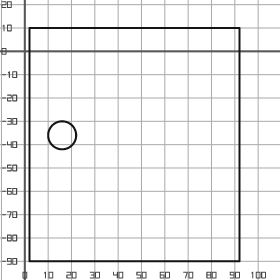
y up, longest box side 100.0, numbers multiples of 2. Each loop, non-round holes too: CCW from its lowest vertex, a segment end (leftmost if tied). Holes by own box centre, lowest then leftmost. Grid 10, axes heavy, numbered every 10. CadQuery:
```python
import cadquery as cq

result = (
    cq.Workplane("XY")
    .moveTo(2.0, -90.0)
    .lineTo(92.0, -90.0)
    .lineTo(92.0, 10.0)
    .lineTo(2.0, 10.0)
    .close()
    .moveTo(16.0, -36.0)
    .circle(6.0)
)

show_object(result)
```